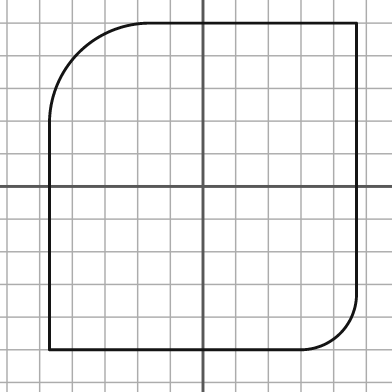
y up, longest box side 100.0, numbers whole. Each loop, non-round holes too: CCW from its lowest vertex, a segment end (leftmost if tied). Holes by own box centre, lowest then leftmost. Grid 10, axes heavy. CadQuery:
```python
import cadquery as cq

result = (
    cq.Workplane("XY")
    .moveTo(-47.0, -50.0)
    .lineTo(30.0, -50.0)
    .threePointArc((42.0, -45.0), (47.0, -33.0))
    .lineTo(47.0, 50.0)
    .lineTo(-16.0, 50.0)
    .threePointArc((-38.0, 41.0), (-47.0, 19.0))
    .close()
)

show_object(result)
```